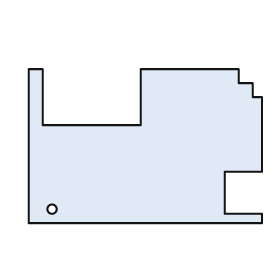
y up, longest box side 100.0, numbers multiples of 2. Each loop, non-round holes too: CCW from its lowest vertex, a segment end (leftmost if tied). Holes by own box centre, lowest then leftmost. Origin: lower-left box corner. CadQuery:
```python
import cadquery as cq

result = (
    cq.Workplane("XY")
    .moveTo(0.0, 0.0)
    .lineTo(100.0, 0.0)
    .lineTo(100.0, 4.0)
    .lineTo(84.0, 4.0)
    .lineTo(84.0, 22.0)
    .lineTo(100.0, 22.0)
    .lineTo(100.0, 54.0)
    .lineTo(96.0, 54.0)
    .lineTo(96.0, 60.0)
    .lineTo(90.0, 60.0)
    .lineTo(90.0, 66.0)
    .lineTo(48.0, 66.0)
    .lineTo(48.0, 42.0)
    .lineTo(6.0, 42.0)
    .lineTo(6.0, 66.0)
    .lineTo(0.0, 66.0)
    .close()
    .moveTo(10.0, 6.0)
    .circle(2.0)
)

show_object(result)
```